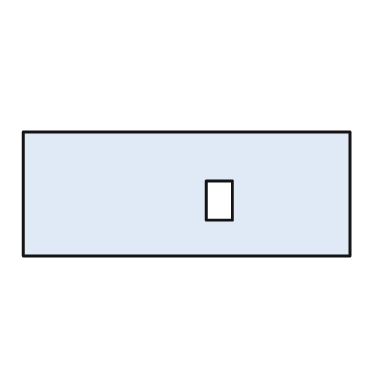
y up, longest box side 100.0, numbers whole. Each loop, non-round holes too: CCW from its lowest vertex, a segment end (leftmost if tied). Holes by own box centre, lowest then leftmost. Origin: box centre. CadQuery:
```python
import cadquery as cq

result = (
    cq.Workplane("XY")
    .moveTo(-50.0, -19.0)
    .lineTo(50.0, -19.0)
    .lineTo(50.0, 19.0)
    .lineTo(-50.0, 19.0)
    .close()
    .moveTo(6.0, -8.0)
    .lineTo(14.0, -8.0)
    .lineTo(14.0, 4.0)
    .lineTo(6.0, 4.0)
    .close()
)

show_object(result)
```